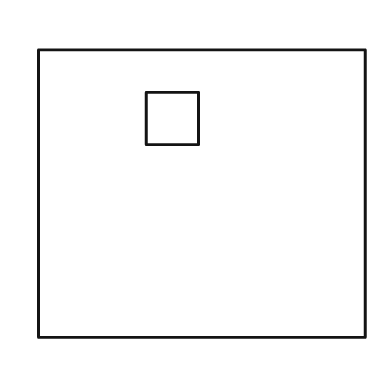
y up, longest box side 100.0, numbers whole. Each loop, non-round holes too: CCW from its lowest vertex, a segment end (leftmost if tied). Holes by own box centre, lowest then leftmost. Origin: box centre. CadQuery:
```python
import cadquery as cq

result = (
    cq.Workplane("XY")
    .moveTo(-50.0, -44.0)
    .lineTo(50.0, -44.0)
    .lineTo(50.0, 44.0)
    .lineTo(-50.0, 44.0)
    .close()
    .moveTo(-17.0, 15.0)
    .lineTo(-1.0, 15.0)
    .lineTo(-1.0, 31.0)
    .lineTo(-17.0, 31.0)
    .close()
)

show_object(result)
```